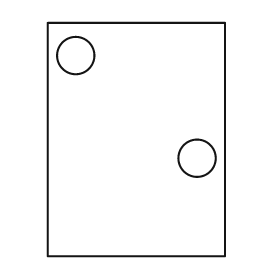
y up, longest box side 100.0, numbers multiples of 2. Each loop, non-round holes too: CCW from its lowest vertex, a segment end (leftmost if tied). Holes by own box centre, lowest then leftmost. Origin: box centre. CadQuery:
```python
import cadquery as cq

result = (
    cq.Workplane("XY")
    .moveTo(-38.0, -50.0)
    .lineTo(38.0, -50.0)
    .lineTo(38.0, 50.0)
    .lineTo(-38.0, 50.0)
    .close()
    .moveTo(26.0, -8.0)
    .circle(8.0)
    .moveTo(-26.0, 36.0)
    .circle(8.0)
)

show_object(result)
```